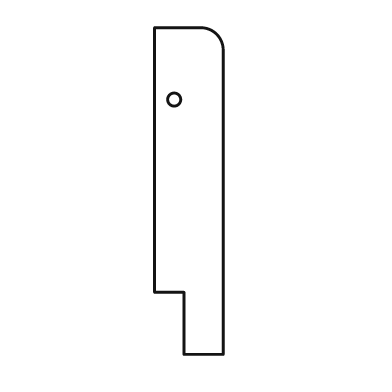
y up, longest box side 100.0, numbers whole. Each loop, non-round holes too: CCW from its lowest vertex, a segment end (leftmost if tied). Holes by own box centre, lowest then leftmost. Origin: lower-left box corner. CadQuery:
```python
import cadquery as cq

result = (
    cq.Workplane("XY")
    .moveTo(9.0, 0.0)
    .lineTo(21.0, 0.0)
    .lineTo(21.0, 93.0)
    .threePointArc((19.0, 98.0), (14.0, 100.0))
    .lineTo(0.0, 100.0)
    .lineTo(0.0, 19.0)
    .lineTo(9.0, 19.0)
    .close()
    .moveTo(6.0, 78.0)
    .circle(2.0)
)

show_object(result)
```